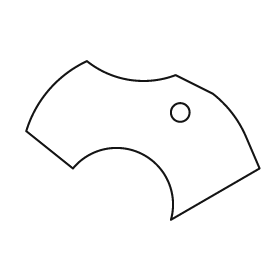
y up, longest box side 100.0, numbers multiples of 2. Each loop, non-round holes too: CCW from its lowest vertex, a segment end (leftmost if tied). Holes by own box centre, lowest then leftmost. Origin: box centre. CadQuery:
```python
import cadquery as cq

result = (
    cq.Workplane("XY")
    .moveTo(12.0, -34.0)
    .lineTo(50.0, -12.0)
    .lineTo(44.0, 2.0)
    .threePointArc((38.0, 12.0), (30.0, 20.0))
    .lineTo(14.0, 28.0)
    .threePointArc((-6.0, 26.0), (-24.0, 34.0))
    .threePointArc((-40.0, 22.0), (-50.0, 4.0))
    .lineTo(-30.0, -12.0)
    .threePointArc((0.0, -6.0), (12.0, -34.0))
    .close()
    .moveTo(16.0, 12.0)
    .circle(4.0)
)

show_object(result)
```